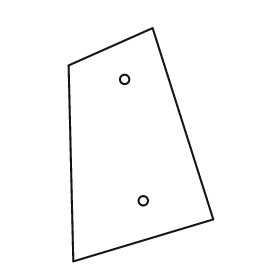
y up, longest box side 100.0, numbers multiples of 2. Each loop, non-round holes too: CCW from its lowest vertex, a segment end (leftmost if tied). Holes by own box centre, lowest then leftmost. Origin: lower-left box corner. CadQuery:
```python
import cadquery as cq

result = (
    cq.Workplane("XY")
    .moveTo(2.0, 0.0)
    .lineTo(62.0, 18.0)
    .lineTo(36.0, 100.0)
    .lineTo(0.0, 84.0)
    .close()
    .moveTo(32.0, 26.0)
    .circle(2.0)
    .moveTo(24.0, 78.0)
    .circle(2.0)
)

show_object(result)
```